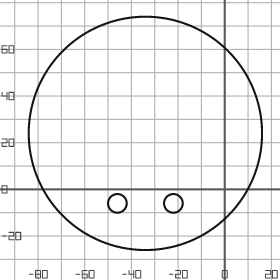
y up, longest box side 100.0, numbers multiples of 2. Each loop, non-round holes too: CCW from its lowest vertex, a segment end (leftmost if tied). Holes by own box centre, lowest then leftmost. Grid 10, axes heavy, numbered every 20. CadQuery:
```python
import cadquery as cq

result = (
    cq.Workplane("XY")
    .moveTo(-34.0, 24.0)
    .circle(50.0)
    .moveTo(-46.0, -6.0)
    .circle(4.0)
    .moveTo(-22.0, -6.0)
    .circle(4.0)
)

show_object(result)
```